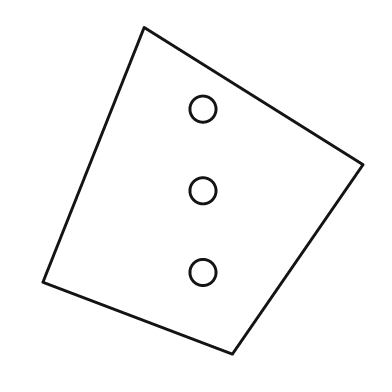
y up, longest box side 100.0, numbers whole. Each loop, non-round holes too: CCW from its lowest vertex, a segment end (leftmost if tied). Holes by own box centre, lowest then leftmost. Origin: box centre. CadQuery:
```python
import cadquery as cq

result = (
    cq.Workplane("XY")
    .moveTo(9.0, -50.0)
    .lineTo(49.0, 8.0)
    .lineTo(-18.0, 50.0)
    .lineTo(-49.0, -28.0)
    .close()
    .moveTo(0.0, -25.0)
    .circle(4.0)
    .moveTo(0.0, 0.0)
    .circle(4.0)
    .moveTo(0.0, 25.0)
    .circle(4.0)
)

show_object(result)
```